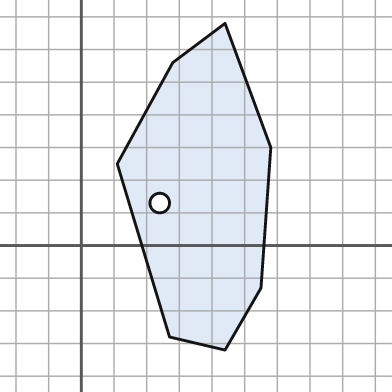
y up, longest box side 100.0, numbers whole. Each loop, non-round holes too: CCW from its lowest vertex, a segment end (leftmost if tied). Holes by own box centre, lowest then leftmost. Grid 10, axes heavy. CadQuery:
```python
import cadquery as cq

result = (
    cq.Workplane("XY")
    .moveTo(44.0, -32.0)
    .lineTo(55.0, -13.0)
    .lineTo(58.0, 30.0)
    .lineTo(44.0, 68.0)
    .lineTo(28.0, 56.0)
    .lineTo(11.0, 25.0)
    .lineTo(27.0, -28.0)
    .close()
    .moveTo(24.0, 13.0)
    .circle(3.0)
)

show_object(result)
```